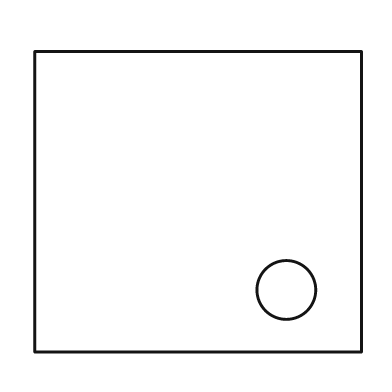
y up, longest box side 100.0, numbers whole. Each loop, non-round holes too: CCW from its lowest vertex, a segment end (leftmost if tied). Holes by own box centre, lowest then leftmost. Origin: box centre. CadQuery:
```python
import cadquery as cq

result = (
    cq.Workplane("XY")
    .moveTo(-50.0, -46.0)
    .lineTo(50.0, -46.0)
    .lineTo(50.0, 46.0)
    .lineTo(-50.0, 46.0)
    .close()
    .moveTo(27.0, -27.0)
    .circle(9.0)
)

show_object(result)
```